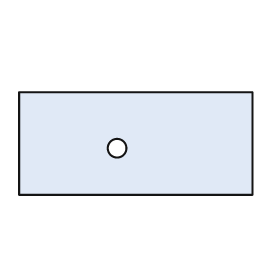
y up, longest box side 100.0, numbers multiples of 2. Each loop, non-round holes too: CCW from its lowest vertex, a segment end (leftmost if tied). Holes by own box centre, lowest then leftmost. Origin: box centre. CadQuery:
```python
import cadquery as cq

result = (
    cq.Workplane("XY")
    .moveTo(-50.0, -22.0)
    .lineTo(50.0, -22.0)
    .lineTo(50.0, 22.0)
    .lineTo(-50.0, 22.0)
    .close()
    .moveTo(-8.0, -2.0)
    .circle(4.0)
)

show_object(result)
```